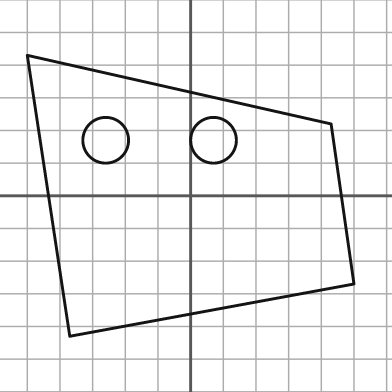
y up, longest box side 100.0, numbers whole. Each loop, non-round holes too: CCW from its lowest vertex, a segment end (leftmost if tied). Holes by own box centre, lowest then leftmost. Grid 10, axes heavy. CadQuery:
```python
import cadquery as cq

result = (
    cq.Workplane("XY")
    .moveTo(-37.0, -43.0)
    .lineTo(50.0, -27.0)
    .lineTo(43.0, 22.0)
    .lineTo(-50.0, 43.0)
    .close()
    .moveTo(-26.0, 17.0)
    .circle(7.0)
    .moveTo(7.0, 17.0)
    .circle(7.0)
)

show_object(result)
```